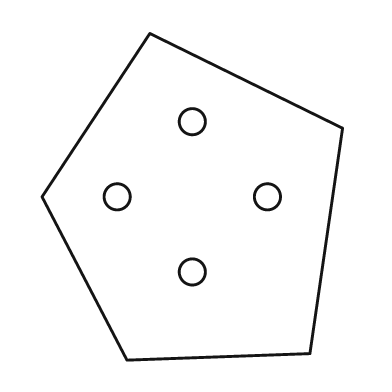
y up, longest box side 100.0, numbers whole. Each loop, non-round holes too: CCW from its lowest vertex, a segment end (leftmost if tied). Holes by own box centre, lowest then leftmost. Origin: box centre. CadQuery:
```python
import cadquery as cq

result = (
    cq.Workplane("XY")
    .moveTo(-20.0, -50.0)
    .lineTo(36.0, -48.0)
    .lineTo(46.0, 21.0)
    .lineTo(-13.0, 50.0)
    .lineTo(-46.0, 0.0)
    .close()
    .moveTo(0.0, -23.0)
    .circle(4.0)
    .moveTo(-23.0, 0.0)
    .circle(4.0)
    .moveTo(23.0, 0.0)
    .circle(4.0)
    .moveTo(0.0, 23.0)
    .circle(4.0)
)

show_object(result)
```